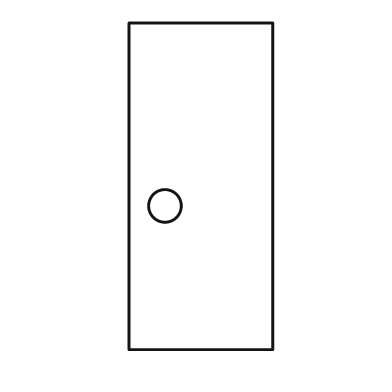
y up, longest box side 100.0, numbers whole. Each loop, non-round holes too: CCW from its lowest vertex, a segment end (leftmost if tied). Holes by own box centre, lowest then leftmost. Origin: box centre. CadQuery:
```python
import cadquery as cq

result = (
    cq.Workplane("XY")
    .moveTo(-22.0, -50.0)
    .lineTo(22.0, -50.0)
    .lineTo(22.0, 50.0)
    .lineTo(-22.0, 50.0)
    .close()
    .moveTo(-11.0, -6.0)
    .circle(5.0)
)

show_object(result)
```